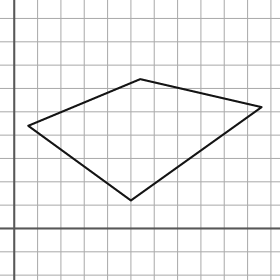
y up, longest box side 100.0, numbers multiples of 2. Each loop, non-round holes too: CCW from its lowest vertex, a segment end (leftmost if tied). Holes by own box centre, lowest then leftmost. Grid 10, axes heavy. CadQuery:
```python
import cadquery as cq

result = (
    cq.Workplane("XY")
    .moveTo(50.0, 12.0)
    .lineTo(106.0, 52.0)
    .lineTo(54.0, 64.0)
    .lineTo(6.0, 44.0)
    .close()
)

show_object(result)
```